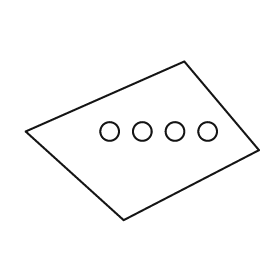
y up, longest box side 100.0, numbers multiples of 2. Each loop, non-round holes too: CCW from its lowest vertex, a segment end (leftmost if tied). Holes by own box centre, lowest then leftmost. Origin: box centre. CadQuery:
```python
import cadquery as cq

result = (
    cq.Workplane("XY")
    .moveTo(-8.0, -34.0)
    .lineTo(50.0, -4.0)
    .lineTo(18.0, 34.0)
    .lineTo(-50.0, 4.0)
    .close()
    .moveTo(-14.0, 4.0)
    .circle(4.0)
    .moveTo(0.0, 4.0)
    .circle(4.0)
    .moveTo(14.0, 4.0)
    .circle(4.0)
    .moveTo(28.0, 4.0)
    .circle(4.0)
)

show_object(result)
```